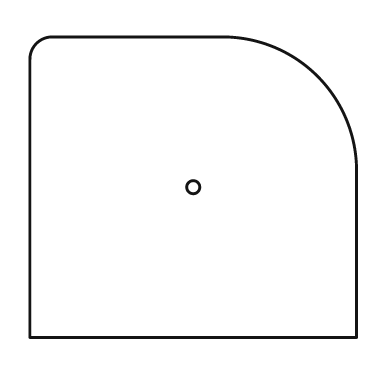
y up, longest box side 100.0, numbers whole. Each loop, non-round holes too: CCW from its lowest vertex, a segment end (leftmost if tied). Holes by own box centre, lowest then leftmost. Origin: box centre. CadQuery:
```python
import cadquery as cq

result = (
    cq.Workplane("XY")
    .moveTo(-50.0, -46.0)
    .lineTo(50.0, -46.0)
    .lineTo(50.0, 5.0)
    .threePointArc((38.0, 34.0), (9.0, 46.0))
    .lineTo(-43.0, 46.0)
    .threePointArc((-48.0, 44.0), (-50.0, 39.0))
    .close()
    .moveTo(0.0, 0.0)
    .circle(2.0)
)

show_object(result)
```